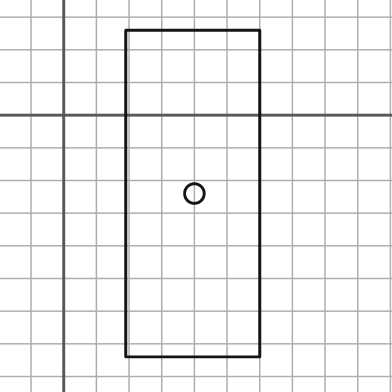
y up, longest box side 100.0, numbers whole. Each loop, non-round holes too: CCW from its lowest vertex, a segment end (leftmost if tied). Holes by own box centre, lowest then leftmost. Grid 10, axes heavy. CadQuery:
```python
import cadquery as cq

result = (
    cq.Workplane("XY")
    .moveTo(19.0, -74.0)
    .lineTo(60.0, -74.0)
    .lineTo(60.0, 26.0)
    .lineTo(19.0, 26.0)
    .close()
    .moveTo(40.0, -24.0)
    .circle(3.0)
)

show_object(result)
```